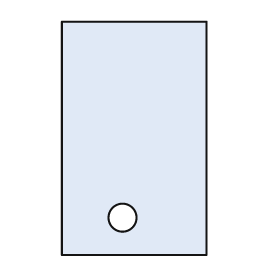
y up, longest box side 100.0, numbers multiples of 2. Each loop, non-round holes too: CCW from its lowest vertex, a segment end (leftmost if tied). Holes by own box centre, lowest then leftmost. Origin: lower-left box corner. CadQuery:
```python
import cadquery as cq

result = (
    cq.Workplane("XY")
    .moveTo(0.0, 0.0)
    .lineTo(62.0, 0.0)
    .lineTo(62.0, 100.0)
    .lineTo(0.0, 100.0)
    .close()
    .moveTo(26.0, 16.0)
    .circle(6.0)
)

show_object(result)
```